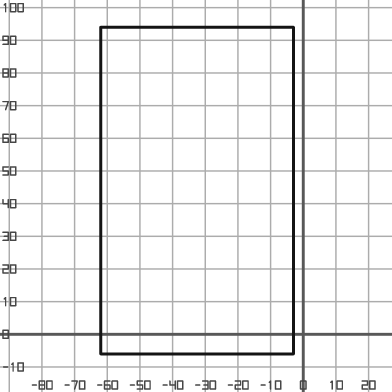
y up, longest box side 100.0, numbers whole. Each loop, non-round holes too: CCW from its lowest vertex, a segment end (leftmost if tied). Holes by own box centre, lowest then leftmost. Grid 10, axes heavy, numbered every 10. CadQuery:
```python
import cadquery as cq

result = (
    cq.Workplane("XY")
    .moveTo(-62.0, -6.0)
    .lineTo(-3.0, -6.0)
    .lineTo(-3.0, 94.0)
    .lineTo(-62.0, 94.0)
    .close()
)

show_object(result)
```